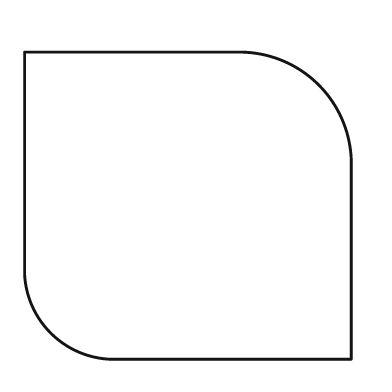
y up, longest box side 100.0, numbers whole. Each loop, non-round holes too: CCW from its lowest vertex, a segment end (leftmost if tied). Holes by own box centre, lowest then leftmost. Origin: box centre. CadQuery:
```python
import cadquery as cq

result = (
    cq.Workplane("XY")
    .moveTo(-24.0, -47.0)
    .lineTo(50.0, -47.0)
    .lineTo(50.0, 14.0)
    .threePointArc((40.0, 37.0), (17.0, 47.0))
    .lineTo(-50.0, 47.0)
    .lineTo(-50.0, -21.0)
    .threePointArc((-42.0, -39.0), (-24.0, -47.0))
    .close()
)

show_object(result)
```